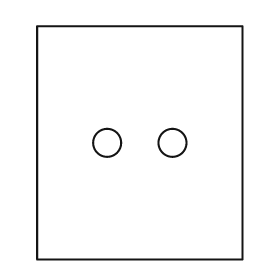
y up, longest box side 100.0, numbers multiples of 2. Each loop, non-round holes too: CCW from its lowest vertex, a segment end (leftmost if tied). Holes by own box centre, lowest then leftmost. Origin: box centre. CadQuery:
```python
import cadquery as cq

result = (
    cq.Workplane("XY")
    .moveTo(-44.0, -50.0)
    .lineTo(44.0, -50.0)
    .lineTo(44.0, 50.0)
    .lineTo(-44.0, 50.0)
    .close()
    .moveTo(-14.0, 0.0)
    .circle(6.0)
    .moveTo(14.0, 0.0)
    .circle(6.0)
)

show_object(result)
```